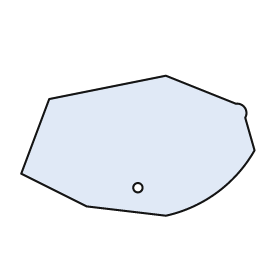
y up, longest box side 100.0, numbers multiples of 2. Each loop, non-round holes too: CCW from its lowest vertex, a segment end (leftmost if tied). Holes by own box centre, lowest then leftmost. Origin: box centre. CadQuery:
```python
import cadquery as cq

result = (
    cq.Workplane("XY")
    .moveTo(12.0, -30.0)
    .threePointArc((34.0, -20.0), (50.0, -2.0))
    .lineTo(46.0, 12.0)
    .threePointArc((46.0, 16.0), (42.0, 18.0))
    .lineTo(12.0, 30.0)
    .lineTo(-38.0, 20.0)
    .lineTo(-50.0, -12.0)
    .lineTo(-22.0, -26.0)
    .close()
    .moveTo(0.0, -18.0)
    .circle(2.0)
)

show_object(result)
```